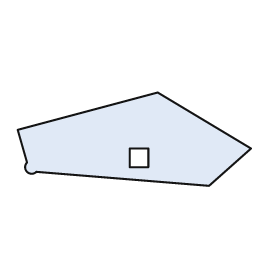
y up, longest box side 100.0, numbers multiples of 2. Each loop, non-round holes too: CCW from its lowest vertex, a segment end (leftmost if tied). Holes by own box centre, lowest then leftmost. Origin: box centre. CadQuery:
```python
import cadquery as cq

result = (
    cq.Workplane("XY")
    .moveTo(32.0, -20.0)
    .lineTo(50.0, -4.0)
    .lineTo(10.0, 20.0)
    .lineTo(-50.0, 4.0)
    .lineTo(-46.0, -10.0)
    .threePointArc((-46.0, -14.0), (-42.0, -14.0))
    .close()
    .moveTo(-2.0, -12.0)
    .lineTo(6.0, -12.0)
    .lineTo(6.0, -4.0)
    .lineTo(-2.0, -4.0)
    .close()
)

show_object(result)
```